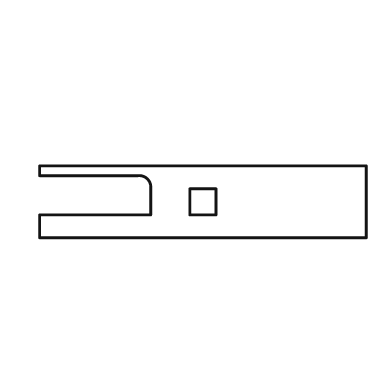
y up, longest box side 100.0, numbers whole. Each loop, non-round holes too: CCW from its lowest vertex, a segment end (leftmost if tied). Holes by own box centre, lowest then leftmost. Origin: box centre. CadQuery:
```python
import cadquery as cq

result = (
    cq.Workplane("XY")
    .moveTo(-50.0, -11.0)
    .lineTo(50.0, -11.0)
    .lineTo(50.0, 11.0)
    .lineTo(-50.0, 11.0)
    .lineTo(-50.0, 8.0)
    .lineTo(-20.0, 8.0)
    .threePointArc((-17.0, 7.0), (-16.0, 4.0))
    .lineTo(-16.0, -4.0)
    .lineTo(-50.0, -4.0)
    .close()
    .moveTo(-4.0, -4.0)
    .lineTo(4.0, -4.0)
    .lineTo(4.0, 4.0)
    .lineTo(-4.0, 4.0)
    .close()
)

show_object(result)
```